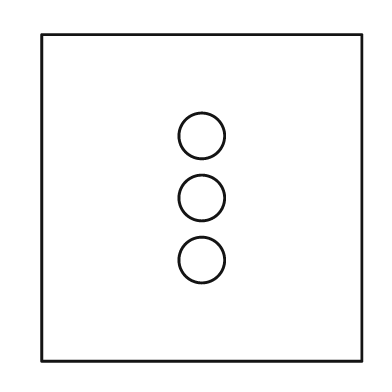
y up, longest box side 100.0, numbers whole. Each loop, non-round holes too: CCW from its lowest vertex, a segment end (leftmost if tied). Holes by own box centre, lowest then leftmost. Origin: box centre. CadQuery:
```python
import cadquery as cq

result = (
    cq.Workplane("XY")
    .moveTo(-49.0, -50.0)
    .lineTo(49.0, -50.0)
    .lineTo(49.0, 50.0)
    .lineTo(-49.0, 50.0)
    .close()
    .moveTo(0.0, -19.0)
    .circle(7.0)
    .moveTo(0.0, 0.0)
    .circle(7.0)
    .moveTo(0.0, 19.0)
    .circle(7.0)
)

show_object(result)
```